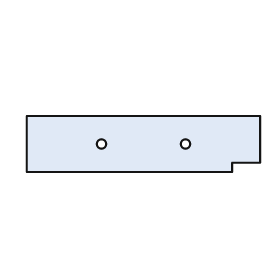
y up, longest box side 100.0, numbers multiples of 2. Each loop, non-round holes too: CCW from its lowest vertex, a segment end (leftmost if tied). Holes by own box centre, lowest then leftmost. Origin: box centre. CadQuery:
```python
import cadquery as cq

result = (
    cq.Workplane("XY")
    .moveTo(-50.0, -12.0)
    .lineTo(38.0, -12.0)
    .lineTo(38.0, -8.0)
    .lineTo(50.0, -8.0)
    .lineTo(50.0, 12.0)
    .lineTo(-50.0, 12.0)
    .close()
    .moveTo(-18.0, 0.0)
    .circle(2.0)
    .moveTo(18.0, 0.0)
    .circle(2.0)
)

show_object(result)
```